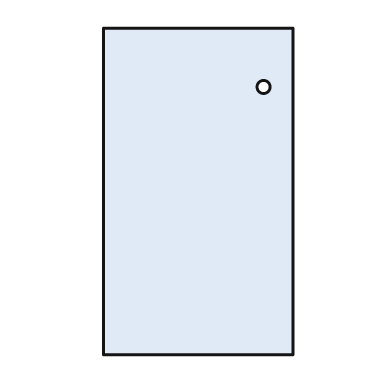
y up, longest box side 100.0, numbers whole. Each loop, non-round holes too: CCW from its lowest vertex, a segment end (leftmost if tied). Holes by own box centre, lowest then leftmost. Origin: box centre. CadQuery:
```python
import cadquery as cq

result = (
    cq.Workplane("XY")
    .moveTo(-29.0, -50.0)
    .lineTo(29.0, -50.0)
    .lineTo(29.0, 50.0)
    .lineTo(-29.0, 50.0)
    .close()
    .moveTo(20.0, 32.0)
    .circle(2.0)
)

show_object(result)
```